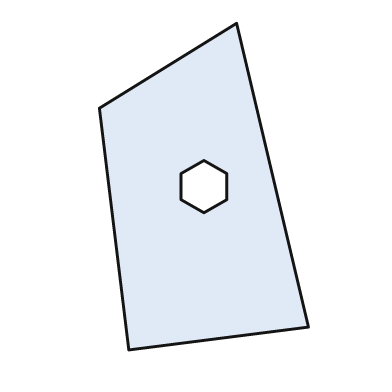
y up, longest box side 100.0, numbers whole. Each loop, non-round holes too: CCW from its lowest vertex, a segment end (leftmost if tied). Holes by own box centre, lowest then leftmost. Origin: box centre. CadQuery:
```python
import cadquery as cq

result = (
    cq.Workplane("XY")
    .moveTo(-23.0, -50.0)
    .lineTo(32.0, -43.0)
    .lineTo(10.0, 50.0)
    .lineTo(-32.0, 24.0)
    .close()
    .moveTo(0.0, -8.0)
    .lineTo(7.0, -4.0)
    .lineTo(7.0, 4.0)
    .lineTo(0.0, 8.0)
    .lineTo(-7.0, 4.0)
    .lineTo(-7.0, -4.0)
    .close()
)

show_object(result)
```